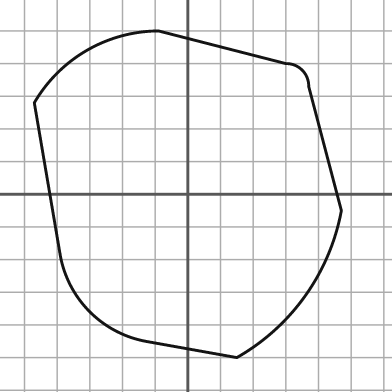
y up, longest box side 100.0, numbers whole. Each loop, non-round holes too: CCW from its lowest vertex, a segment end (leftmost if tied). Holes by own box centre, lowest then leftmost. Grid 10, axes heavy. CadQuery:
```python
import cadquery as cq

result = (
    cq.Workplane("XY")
    .moveTo(15.0, -50.0)
    .threePointArc((36.0, -31.0), (47.0, -5.0))
    .lineTo(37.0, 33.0)
    .threePointArc((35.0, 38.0), (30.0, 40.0))
    .lineTo(-9.0, 50.0)
    .threePointArc((-31.0, 44.0), (-47.0, 28.0))
    .lineTo(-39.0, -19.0)
    .threePointArc((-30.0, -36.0), (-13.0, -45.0))
    .close()
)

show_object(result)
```